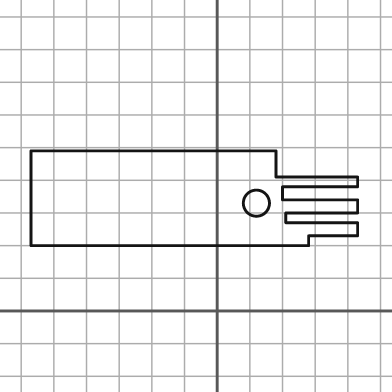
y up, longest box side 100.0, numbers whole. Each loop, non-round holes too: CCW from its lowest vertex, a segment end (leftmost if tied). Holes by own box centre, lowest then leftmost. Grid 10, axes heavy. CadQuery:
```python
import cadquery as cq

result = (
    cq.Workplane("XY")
    .moveTo(-57.0, 20.0)
    .lineTo(28.0, 20.0)
    .lineTo(28.0, 23.0)
    .lineTo(43.0, 23.0)
    .lineTo(43.0, 27.0)
    .lineTo(21.0, 27.0)
    .lineTo(21.0, 30.0)
    .lineTo(43.0, 30.0)
    .lineTo(43.0, 34.0)
    .lineTo(20.0, 34.0)
    .lineTo(20.0, 38.0)
    .lineTo(43.0, 38.0)
    .lineTo(43.0, 41.0)
    .lineTo(18.0, 41.0)
    .lineTo(18.0, 49.0)
    .lineTo(-57.0, 49.0)
    .close()
    .moveTo(12.0, 33.0)
    .circle(4.0)
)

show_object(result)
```